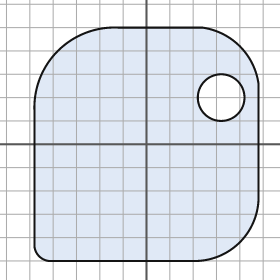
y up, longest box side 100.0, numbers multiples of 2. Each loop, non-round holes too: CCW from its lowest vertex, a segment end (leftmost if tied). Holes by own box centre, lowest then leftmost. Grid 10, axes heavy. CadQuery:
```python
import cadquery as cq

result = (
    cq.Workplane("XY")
    .moveTo(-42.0, -50.0)
    .lineTo(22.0, -50.0)
    .threePointArc((40.0, -42.0), (48.0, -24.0))
    .lineTo(48.0, 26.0)
    .threePointArc((40.0, 42.0), (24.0, 50.0))
    .lineTo(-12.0, 50.0)
    .threePointArc((-38.0, 40.0), (-48.0, 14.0))
    .lineTo(-48.0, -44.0)
    .threePointArc((-46.0, -48.0), (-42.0, -50.0))
    .close()
    .moveTo(32.0, 20.0)
    .circle(10.0)
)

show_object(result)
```